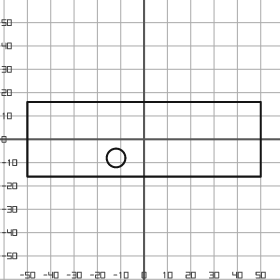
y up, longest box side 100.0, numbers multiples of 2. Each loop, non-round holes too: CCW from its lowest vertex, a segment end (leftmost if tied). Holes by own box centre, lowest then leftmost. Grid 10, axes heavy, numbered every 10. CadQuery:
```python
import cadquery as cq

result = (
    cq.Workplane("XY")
    .moveTo(-50.0, -16.0)
    .lineTo(50.0, -16.0)
    .lineTo(50.0, 16.0)
    .lineTo(-50.0, 16.0)
    .close()
    .moveTo(-12.0, -8.0)
    .circle(4.0)
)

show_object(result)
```